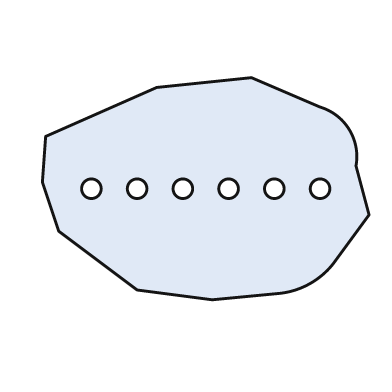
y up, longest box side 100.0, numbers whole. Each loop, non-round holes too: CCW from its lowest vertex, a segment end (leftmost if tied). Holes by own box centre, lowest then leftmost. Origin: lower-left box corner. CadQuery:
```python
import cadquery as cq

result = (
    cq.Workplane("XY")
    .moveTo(52.0, 0.0)
    .lineTo(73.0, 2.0)
    .threePointArc((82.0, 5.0), (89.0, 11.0))
    .lineTo(100.0, 26.0)
    .lineTo(96.0, 41.0)
    .threePointArc((94.0, 52.0), (85.0, 59.0))
    .lineTo(64.0, 68.0)
    .lineTo(35.0, 65.0)
    .lineTo(1.0, 50.0)
    .lineTo(0.0, 36.0)
    .lineTo(5.0, 21.0)
    .lineTo(29.0, 3.0)
    .close()
    .moveTo(15.0, 34.0)
    .circle(3.0)
    .moveTo(29.0, 34.0)
    .circle(3.0)
    .moveTo(43.0, 34.0)
    .circle(3.0)
    .moveTo(57.0, 34.0)
    .circle(3.0)
    .moveTo(71.0, 34.0)
    .circle(3.0)
    .moveTo(85.0, 34.0)
    .circle(3.0)
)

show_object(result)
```